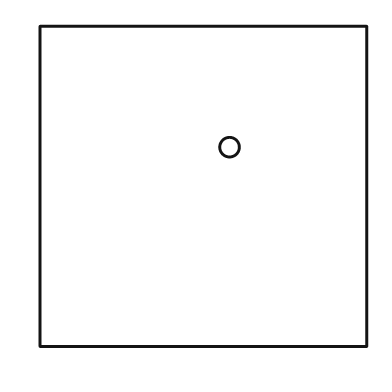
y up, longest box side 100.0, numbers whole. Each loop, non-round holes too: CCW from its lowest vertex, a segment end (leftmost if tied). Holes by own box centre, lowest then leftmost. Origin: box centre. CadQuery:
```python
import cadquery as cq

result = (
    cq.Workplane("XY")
    .moveTo(-50.0, -49.0)
    .lineTo(50.0, -49.0)
    .lineTo(50.0, 49.0)
    .lineTo(-50.0, 49.0)
    .close()
    .moveTo(8.0, 12.0)
    .circle(3.0)
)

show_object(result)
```